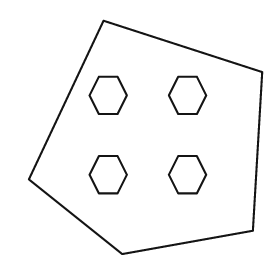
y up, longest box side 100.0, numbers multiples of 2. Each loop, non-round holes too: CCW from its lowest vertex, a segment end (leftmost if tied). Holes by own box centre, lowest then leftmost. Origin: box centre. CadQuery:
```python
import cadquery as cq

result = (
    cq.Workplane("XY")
    .moveTo(-10.0, -50.0)
    .lineTo(46.0, -40.0)
    .lineTo(50.0, 28.0)
    .lineTo(-18.0, 50.0)
    .lineTo(-50.0, -18.0)
    .close()
    .moveTo(-20.0, -24.0)
    .lineTo(-12.0, -24.0)
    .lineTo(-8.0, -16.0)
    .lineTo(-12.0, -8.0)
    .lineTo(-20.0, -8.0)
    .lineTo(-24.0, -16.0)
    .close()
    .moveTo(14.0, -24.0)
    .lineTo(22.0, -24.0)
    .lineTo(26.0, -16.0)
    .lineTo(22.0, -8.0)
    .lineTo(14.0, -8.0)
    .lineTo(10.0, -16.0)
    .close()
    .moveTo(-20.0, 10.0)
    .lineTo(-12.0, 10.0)
    .lineTo(-8.0, 18.0)
    .lineTo(-12.0, 26.0)
    .lineTo(-20.0, 26.0)
    .lineTo(-24.0, 18.0)
    .close()
    .moveTo(14.0, 10.0)
    .lineTo(22.0, 10.0)
    .lineTo(26.0, 18.0)
    .lineTo(22.0, 26.0)
    .lineTo(14.0, 26.0)
    .lineTo(10.0, 18.0)
    .close()
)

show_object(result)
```